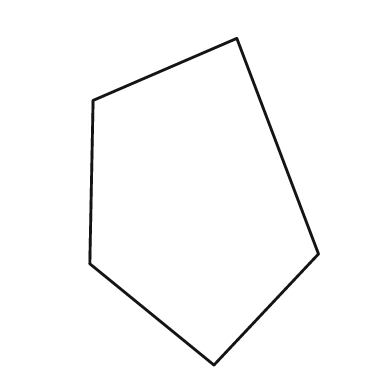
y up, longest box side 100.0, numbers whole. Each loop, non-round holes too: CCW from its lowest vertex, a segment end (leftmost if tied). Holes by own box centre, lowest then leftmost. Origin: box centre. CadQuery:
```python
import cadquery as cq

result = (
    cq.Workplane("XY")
    .moveTo(3.0, -50.0)
    .lineTo(35.0, -16.0)
    .lineTo(10.0, 50.0)
    .lineTo(-34.0, 31.0)
    .lineTo(-35.0, -19.0)
    .close()
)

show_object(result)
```